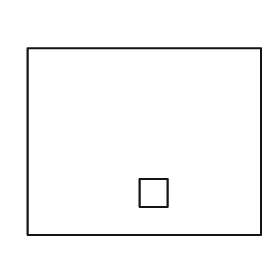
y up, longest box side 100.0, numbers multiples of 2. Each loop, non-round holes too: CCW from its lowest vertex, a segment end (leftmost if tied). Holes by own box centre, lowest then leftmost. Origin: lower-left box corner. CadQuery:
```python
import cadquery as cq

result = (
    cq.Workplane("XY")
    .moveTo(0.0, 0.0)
    .lineTo(100.0, 0.0)
    .lineTo(100.0, 80.0)
    .lineTo(0.0, 80.0)
    .close()
    .moveTo(48.0, 12.0)
    .lineTo(60.0, 12.0)
    .lineTo(60.0, 24.0)
    .lineTo(48.0, 24.0)
    .close()
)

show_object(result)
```